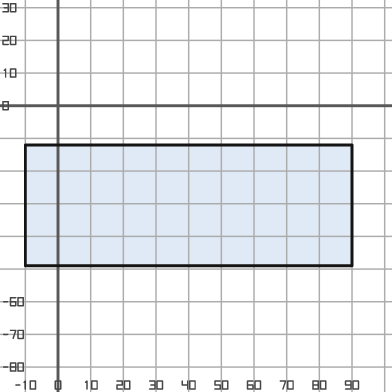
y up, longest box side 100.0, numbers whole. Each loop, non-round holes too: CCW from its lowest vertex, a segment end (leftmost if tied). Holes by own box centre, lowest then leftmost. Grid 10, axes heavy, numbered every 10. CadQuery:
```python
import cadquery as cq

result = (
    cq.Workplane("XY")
    .moveTo(-10.0, -49.0)
    .lineTo(90.0, -49.0)
    .lineTo(90.0, -12.0)
    .lineTo(-10.0, -12.0)
    .close()
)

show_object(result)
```